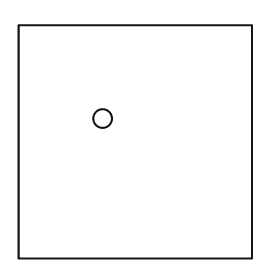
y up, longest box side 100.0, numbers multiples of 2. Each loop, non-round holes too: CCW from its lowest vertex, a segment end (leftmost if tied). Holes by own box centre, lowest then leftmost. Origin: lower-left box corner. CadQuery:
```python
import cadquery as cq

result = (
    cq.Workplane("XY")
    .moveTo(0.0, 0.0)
    .lineTo(100.0, 0.0)
    .lineTo(100.0, 100.0)
    .lineTo(0.0, 100.0)
    .close()
    .moveTo(36.0, 60.0)
    .circle(4.0)
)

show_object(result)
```